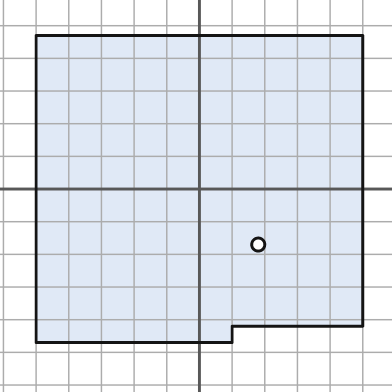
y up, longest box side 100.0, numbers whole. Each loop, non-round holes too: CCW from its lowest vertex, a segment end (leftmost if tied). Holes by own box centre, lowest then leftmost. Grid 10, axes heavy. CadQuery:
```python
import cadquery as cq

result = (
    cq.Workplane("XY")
    .moveTo(-50.0, -47.0)
    .lineTo(10.0, -47.0)
    .lineTo(10.0, -42.0)
    .lineTo(50.0, -42.0)
    .lineTo(50.0, 47.0)
    .lineTo(-50.0, 47.0)
    .close()
    .moveTo(18.0, -17.0)
    .circle(2.0)
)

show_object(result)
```